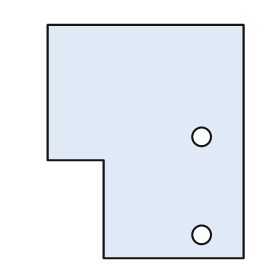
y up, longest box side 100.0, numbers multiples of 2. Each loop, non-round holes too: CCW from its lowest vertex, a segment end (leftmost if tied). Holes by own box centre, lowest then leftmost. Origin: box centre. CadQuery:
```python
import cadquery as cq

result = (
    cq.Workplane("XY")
    .moveTo(-18.0, -50.0)
    .lineTo(42.0, -50.0)
    .lineTo(42.0, 50.0)
    .lineTo(-42.0, 50.0)
    .lineTo(-42.0, -8.0)
    .lineTo(-18.0, -8.0)
    .close()
    .moveTo(24.0, -40.0)
    .circle(4.0)
    .moveTo(24.0, 2.0)
    .circle(4.0)
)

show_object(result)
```